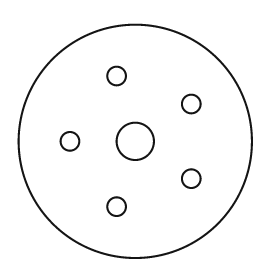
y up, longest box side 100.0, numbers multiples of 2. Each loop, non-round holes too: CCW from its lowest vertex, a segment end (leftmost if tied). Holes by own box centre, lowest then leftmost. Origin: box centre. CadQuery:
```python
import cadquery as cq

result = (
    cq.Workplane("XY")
    .moveTo(0.0, 0.0)
    .circle(50.0)
    .moveTo(-8.0, -28.0)
    .circle(4.0)
    .moveTo(24.0, -16.0)
    .circle(4.0)
    .moveTo(-28.0, 0.0)
    .circle(4.0)
    .moveTo(0.0, 0.0)
    .circle(8.0)
    .moveTo(24.0, 16.0)
    .circle(4.0)
    .moveTo(-8.0, 28.0)
    .circle(4.0)
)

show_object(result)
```